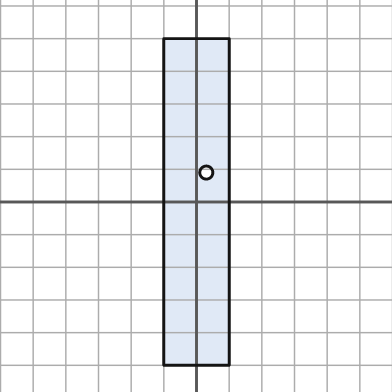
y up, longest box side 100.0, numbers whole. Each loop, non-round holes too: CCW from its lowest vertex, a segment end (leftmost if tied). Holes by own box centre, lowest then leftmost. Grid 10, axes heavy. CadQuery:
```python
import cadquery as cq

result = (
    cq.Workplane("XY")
    .moveTo(-10.0, -50.0)
    .lineTo(10.0, -50.0)
    .lineTo(10.0, 50.0)
    .lineTo(-10.0, 50.0)
    .close()
    .moveTo(3.0, 9.0)
    .circle(2.0)
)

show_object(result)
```